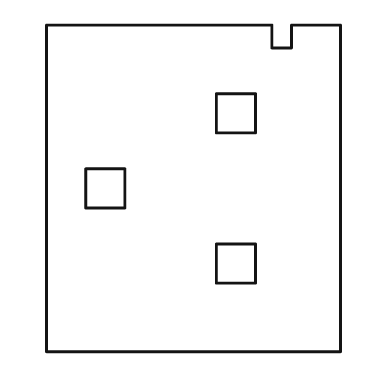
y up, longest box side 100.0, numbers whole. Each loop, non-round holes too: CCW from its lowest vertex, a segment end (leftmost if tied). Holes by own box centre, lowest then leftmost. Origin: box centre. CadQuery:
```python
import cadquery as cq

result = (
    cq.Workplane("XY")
    .moveTo(-45.0, -50.0)
    .lineTo(45.0, -50.0)
    .lineTo(45.0, 50.0)
    .lineTo(30.0, 50.0)
    .lineTo(30.0, 43.0)
    .lineTo(24.0, 43.0)
    .lineTo(24.0, 50.0)
    .lineTo(-45.0, 50.0)
    .close()
    .moveTo(7.0, -29.0)
    .lineTo(19.0, -29.0)
    .lineTo(19.0, -17.0)
    .lineTo(7.0, -17.0)
    .close()
    .moveTo(-33.0, -6.0)
    .lineTo(-21.0, -6.0)
    .lineTo(-21.0, 6.0)
    .lineTo(-33.0, 6.0)
    .close()
    .moveTo(7.0, 17.0)
    .lineTo(19.0, 17.0)
    .lineTo(19.0, 29.0)
    .lineTo(7.0, 29.0)
    .close()
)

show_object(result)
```